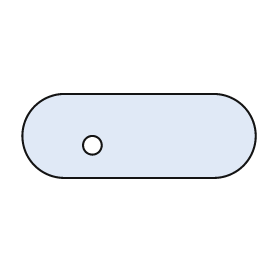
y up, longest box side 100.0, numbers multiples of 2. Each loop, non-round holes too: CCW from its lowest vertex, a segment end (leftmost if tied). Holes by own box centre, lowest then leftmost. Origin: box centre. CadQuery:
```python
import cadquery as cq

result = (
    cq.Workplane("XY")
    .moveTo(-32.0, -18.0)
    .lineTo(32.0, -18.0)
    .threePointArc((50.0, 0.0), (32.0, 18.0))
    .lineTo(-32.0, 18.0)
    .threePointArc((-50.0, 0.0), (-32.0, -18.0))
    .close()
    .moveTo(-20.0, -4.0)
    .circle(4.0)
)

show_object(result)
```